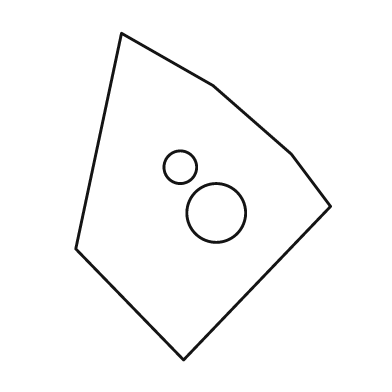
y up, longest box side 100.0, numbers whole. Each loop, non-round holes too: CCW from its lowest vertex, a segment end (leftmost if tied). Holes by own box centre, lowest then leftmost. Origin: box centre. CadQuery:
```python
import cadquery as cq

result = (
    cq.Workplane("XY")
    .moveTo(-6.0, -50.0)
    .lineTo(39.0, -3.0)
    .lineTo(27.0, 13.0)
    .lineTo(3.0, 34.0)
    .lineTo(-25.0, 50.0)
    .lineTo(-39.0, -16.0)
    .close()
    .moveTo(4.0, -5.0)
    .circle(9.0)
    .moveTo(-7.0, 9.0)
    .circle(5.0)
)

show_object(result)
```